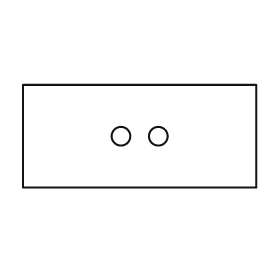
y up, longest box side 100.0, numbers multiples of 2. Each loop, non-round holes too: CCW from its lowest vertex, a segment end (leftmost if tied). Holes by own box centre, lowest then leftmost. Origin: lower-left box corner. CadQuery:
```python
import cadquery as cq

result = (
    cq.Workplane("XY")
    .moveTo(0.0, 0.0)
    .lineTo(100.0, 0.0)
    .lineTo(100.0, 44.0)
    .lineTo(0.0, 44.0)
    .close()
    .moveTo(42.0, 22.0)
    .circle(4.0)
    .moveTo(58.0, 22.0)
    .circle(4.0)
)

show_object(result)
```